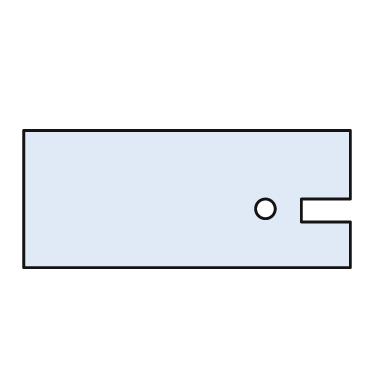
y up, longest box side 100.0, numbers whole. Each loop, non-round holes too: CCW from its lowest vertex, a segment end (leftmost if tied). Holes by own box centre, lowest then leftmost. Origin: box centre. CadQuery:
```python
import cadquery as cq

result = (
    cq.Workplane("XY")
    .moveTo(-50.0, -21.0)
    .lineTo(50.0, -21.0)
    .lineTo(50.0, -7.0)
    .lineTo(35.0, -7.0)
    .lineTo(35.0, 0.0)
    .lineTo(50.0, 0.0)
    .lineTo(50.0, 21.0)
    .lineTo(-50.0, 21.0)
    .close()
    .moveTo(24.0, -3.0)
    .circle(3.0)
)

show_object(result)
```